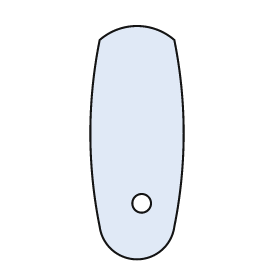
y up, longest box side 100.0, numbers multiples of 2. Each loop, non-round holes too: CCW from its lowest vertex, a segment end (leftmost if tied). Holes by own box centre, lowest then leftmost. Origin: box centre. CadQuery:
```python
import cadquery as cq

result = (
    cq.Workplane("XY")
    .moveTo(-16.0, -36.0)
    .threePointArc((0.0, -50.0), (16.0, -36.0))
    .threePointArc((20.0, 4.0), (16.0, 44.0))
    .threePointArc((0.0, 50.0), (-16.0, 44.0))
    .threePointArc((-20.0, 4.0), (-16.0, -36.0))
    .close()
    .moveTo(2.0, -26.0)
    .circle(4.0)
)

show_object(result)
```